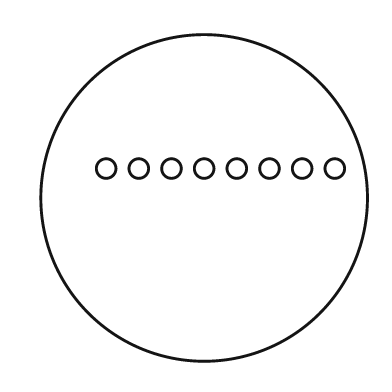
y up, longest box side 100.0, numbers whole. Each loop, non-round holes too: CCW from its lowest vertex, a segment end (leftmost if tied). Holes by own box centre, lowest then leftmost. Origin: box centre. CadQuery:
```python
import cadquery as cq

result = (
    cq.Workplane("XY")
    .moveTo(0.0, 0.0)
    .circle(50.0)
    .moveTo(-30.0, 9.0)
    .circle(3.0)
    .moveTo(-20.0, 9.0)
    .circle(3.0)
    .moveTo(-10.0, 9.0)
    .circle(3.0)
    .moveTo(0.0, 9.0)
    .circle(3.0)
    .moveTo(10.0, 9.0)
    .circle(3.0)
    .moveTo(20.0, 9.0)
    .circle(3.0)
    .moveTo(30.0, 9.0)
    .circle(3.0)
    .moveTo(40.0, 9.0)
    .circle(3.0)
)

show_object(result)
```